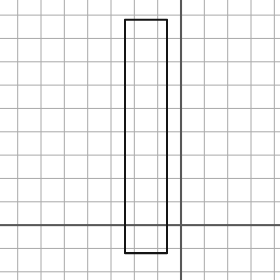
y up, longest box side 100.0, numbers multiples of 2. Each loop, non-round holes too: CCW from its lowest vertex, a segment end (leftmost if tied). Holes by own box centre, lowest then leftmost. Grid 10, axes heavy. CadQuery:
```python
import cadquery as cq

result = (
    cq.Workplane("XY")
    .moveTo(-24.0, -12.0)
    .lineTo(-6.0, -12.0)
    .lineTo(-6.0, 88.0)
    .lineTo(-24.0, 88.0)
    .close()
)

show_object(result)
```